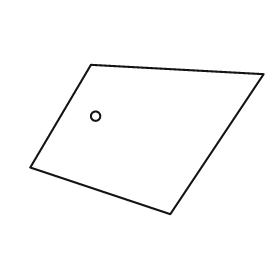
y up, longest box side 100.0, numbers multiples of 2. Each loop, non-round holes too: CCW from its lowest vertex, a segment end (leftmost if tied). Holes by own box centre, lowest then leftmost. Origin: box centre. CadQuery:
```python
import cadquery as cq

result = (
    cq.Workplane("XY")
    .moveTo(10.0, -32.0)
    .lineTo(50.0, 28.0)
    .lineTo(-24.0, 32.0)
    .lineTo(-50.0, -12.0)
    .close()
    .moveTo(-22.0, 10.0)
    .circle(2.0)
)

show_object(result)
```